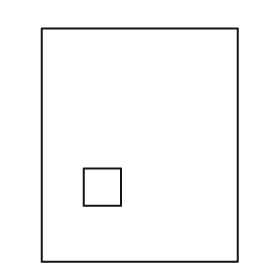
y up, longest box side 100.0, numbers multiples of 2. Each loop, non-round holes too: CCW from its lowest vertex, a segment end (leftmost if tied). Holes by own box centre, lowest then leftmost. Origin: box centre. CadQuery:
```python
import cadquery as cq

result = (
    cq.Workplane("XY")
    .moveTo(-42.0, -50.0)
    .lineTo(42.0, -50.0)
    .lineTo(42.0, 50.0)
    .lineTo(-42.0, 50.0)
    .close()
    .moveTo(-24.0, -26.0)
    .lineTo(-8.0, -26.0)
    .lineTo(-8.0, -10.0)
    .lineTo(-24.0, -10.0)
    .close()
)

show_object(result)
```